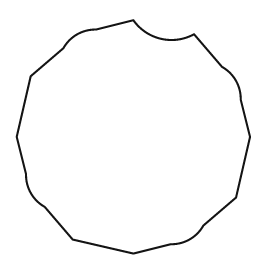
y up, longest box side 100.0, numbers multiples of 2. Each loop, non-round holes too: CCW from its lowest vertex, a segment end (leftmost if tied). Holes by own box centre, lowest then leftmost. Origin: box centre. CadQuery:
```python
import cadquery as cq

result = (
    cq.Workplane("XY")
    .moveTo(0.0, -50.0)
    .lineTo(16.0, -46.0)
    .threePointArc((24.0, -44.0), (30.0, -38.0))
    .lineTo(44.0, -26.0)
    .lineTo(50.0, 0.0)
    .lineTo(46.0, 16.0)
    .threePointArc((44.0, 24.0), (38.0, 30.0))
    .lineTo(26.0, 44.0)
    .threePointArc((12.0, 42.0), (0.0, 50.0))
    .lineTo(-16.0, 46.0)
    .threePointArc((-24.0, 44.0), (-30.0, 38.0))
    .lineTo(-44.0, 26.0)
    .lineTo(-50.0, 0.0)
    .lineTo(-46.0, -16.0)
    .threePointArc((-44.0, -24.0), (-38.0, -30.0))
    .lineTo(-26.0, -44.0)
    .close()
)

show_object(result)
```